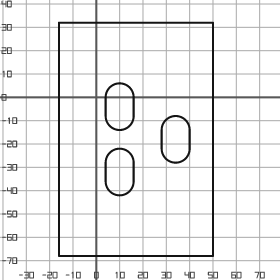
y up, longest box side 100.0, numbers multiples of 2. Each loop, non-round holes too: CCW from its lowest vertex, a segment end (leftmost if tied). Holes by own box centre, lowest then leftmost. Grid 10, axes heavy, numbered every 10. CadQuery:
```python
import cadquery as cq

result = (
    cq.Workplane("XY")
    .moveTo(-16.0, -68.0)
    .lineTo(50.0, -68.0)
    .lineTo(50.0, 32.0)
    .lineTo(-16.0, 32.0)
    .close()
    .moveTo(4.0, -36.0)
    .threePointArc((10.0, -42.0), (16.0, -36.0))
    .lineTo(16.0, -28.0)
    .threePointArc((10.0, -22.0), (4.0, -28.0))
    .close()
    .moveTo(28.0, -22.0)
    .threePointArc((34.0, -28.0), (40.0, -22.0))
    .lineTo(40.0, -14.0)
    .threePointArc((34.0, -8.0), (28.0, -14.0))
    .close()
    .moveTo(4.0, -8.0)
    .threePointArc((10.0, -14.0), (16.0, -8.0))
    .lineTo(16.0, 0.0)
    .threePointArc((10.0, 6.0), (4.0, 0.0))
    .close()
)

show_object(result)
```